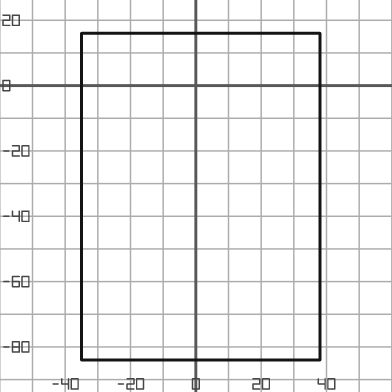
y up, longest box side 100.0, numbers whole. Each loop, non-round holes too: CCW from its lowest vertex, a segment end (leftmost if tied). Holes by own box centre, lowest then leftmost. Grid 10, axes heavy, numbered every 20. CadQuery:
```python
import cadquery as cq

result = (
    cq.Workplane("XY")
    .moveTo(-35.0, -84.0)
    .lineTo(38.0, -84.0)
    .lineTo(38.0, 16.0)
    .lineTo(-35.0, 16.0)
    .close()
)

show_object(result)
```